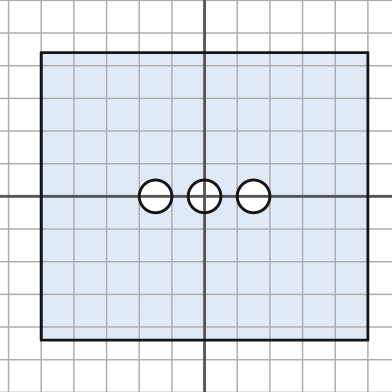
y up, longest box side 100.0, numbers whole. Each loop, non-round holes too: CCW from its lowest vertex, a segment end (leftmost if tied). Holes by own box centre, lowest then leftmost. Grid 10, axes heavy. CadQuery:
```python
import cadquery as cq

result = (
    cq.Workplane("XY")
    .moveTo(-50.0, -44.0)
    .lineTo(50.0, -44.0)
    .lineTo(50.0, 44.0)
    .lineTo(-50.0, 44.0)
    .close()
    .moveTo(-15.0, 0.0)
    .circle(5.0)
    .moveTo(0.0, 0.0)
    .circle(5.0)
    .moveTo(15.0, 0.0)
    .circle(5.0)
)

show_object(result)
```